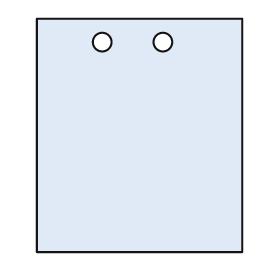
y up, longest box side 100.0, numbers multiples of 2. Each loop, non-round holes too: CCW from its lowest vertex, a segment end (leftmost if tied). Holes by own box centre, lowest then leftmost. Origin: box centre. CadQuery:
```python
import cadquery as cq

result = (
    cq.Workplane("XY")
    .moveTo(-44.0, -50.0)
    .lineTo(44.0, -50.0)
    .lineTo(44.0, 50.0)
    .lineTo(-44.0, 50.0)
    .close()
    .moveTo(-16.0, 40.0)
    .circle(4.0)
    .moveTo(10.0, 40.0)
    .circle(4.0)
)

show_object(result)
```